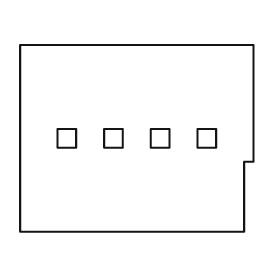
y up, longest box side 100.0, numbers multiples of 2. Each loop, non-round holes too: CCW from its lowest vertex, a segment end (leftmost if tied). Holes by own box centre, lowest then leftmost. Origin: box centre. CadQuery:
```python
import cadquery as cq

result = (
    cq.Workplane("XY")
    .moveTo(-50.0, -40.0)
    .lineTo(46.0, -40.0)
    .lineTo(46.0, -10.0)
    .lineTo(50.0, -10.0)
    .lineTo(50.0, 40.0)
    .lineTo(-50.0, 40.0)
    .close()
    .moveTo(-34.0, -4.0)
    .lineTo(-26.0, -4.0)
    .lineTo(-26.0, 4.0)
    .lineTo(-34.0, 4.0)
    .close()
    .moveTo(-14.0, -4.0)
    .lineTo(-6.0, -4.0)
    .lineTo(-6.0, 4.0)
    .lineTo(-14.0, 4.0)
    .close()
    .moveTo(6.0, -4.0)
    .lineTo(14.0, -4.0)
    .lineTo(14.0, 4.0)
    .lineTo(6.0, 4.0)
    .close()
    .moveTo(26.0, -4.0)
    .lineTo(34.0, -4.0)
    .lineTo(34.0, 4.0)
    .lineTo(26.0, 4.0)
    .close()
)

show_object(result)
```